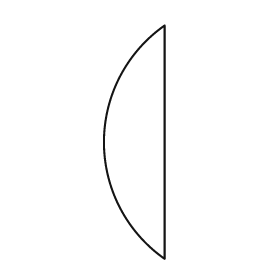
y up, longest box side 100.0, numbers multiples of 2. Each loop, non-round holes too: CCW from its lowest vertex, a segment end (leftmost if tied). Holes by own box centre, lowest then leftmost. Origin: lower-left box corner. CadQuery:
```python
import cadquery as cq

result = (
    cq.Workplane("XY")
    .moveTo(26.0, 0.0)
    .lineTo(26.0, 100.0)
    .threePointArc((0.0, 50.0), (26.0, 0.0))
    .close()
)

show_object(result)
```